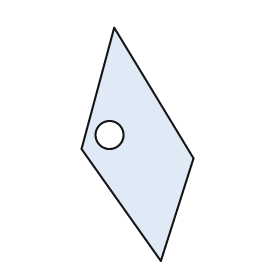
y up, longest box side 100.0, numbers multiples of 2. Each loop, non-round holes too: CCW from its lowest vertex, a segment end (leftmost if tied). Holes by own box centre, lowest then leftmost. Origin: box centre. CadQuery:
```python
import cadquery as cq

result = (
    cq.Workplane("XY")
    .moveTo(10.0, -50.0)
    .lineTo(24.0, -6.0)
    .lineTo(-10.0, 50.0)
    .lineTo(-24.0, -2.0)
    .close()
    .moveTo(-12.0, 4.0)
    .circle(6.0)
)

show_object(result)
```